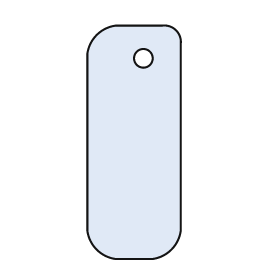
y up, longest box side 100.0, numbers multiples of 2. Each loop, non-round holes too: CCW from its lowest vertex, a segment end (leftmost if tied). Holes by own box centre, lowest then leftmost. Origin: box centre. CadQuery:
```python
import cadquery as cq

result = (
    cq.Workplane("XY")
    .moveTo(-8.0, -50.0)
    .lineTo(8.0, -50.0)
    .threePointArc((16.0, -46.0), (20.0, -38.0))
    .lineTo(20.0, 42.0)
    .threePointArc((18.0, 48.0), (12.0, 50.0))
    .lineTo(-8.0, 50.0)
    .threePointArc((-16.0, 46.0), (-20.0, 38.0))
    .lineTo(-20.0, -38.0)
    .threePointArc((-16.0, -46.0), (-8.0, -50.0))
    .close()
    .moveTo(4.0, 36.0)
    .circle(4.0)
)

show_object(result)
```